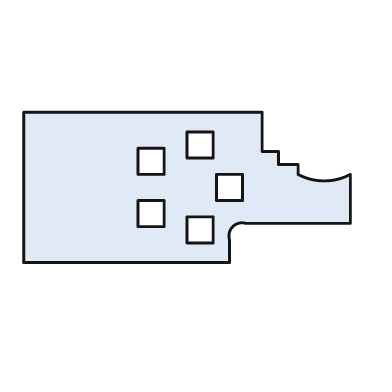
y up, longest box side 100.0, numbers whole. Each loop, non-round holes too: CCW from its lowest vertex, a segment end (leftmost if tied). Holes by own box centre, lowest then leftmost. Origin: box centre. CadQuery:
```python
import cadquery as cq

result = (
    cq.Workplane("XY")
    .moveTo(-50.0, -23.0)
    .lineTo(13.0, -23.0)
    .lineTo(13.0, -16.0)
    .threePointArc((14.0, -12.0), (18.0, -11.0))
    .lineTo(50.0, -11.0)
    .lineTo(50.0, 4.0)
    .threePointArc((42.0, 2.0), (34.0, 4.0))
    .lineTo(34.0, 7.0)
    .lineTo(28.0, 7.0)
    .lineTo(28.0, 11.0)
    .lineTo(23.0, 11.0)
    .lineTo(23.0, 23.0)
    .lineTo(-50.0, 23.0)
    .close()
    .moveTo(0.0, -17.0)
    .lineTo(8.0, -17.0)
    .lineTo(8.0, -9.0)
    .lineTo(0.0, -9.0)
    .close()
    .moveTo(-15.0, -12.0)
    .lineTo(-7.0, -12.0)
    .lineTo(-7.0, -4.0)
    .lineTo(-15.0, -4.0)
    .close()
    .moveTo(9.0, -4.0)
    .lineTo(17.0, -4.0)
    .lineTo(17.0, 4.0)
    .lineTo(9.0, 4.0)
    .close()
    .moveTo(-15.0, 4.0)
    .lineTo(-7.0, 4.0)
    .lineTo(-7.0, 12.0)
    .lineTo(-15.0, 12.0)
    .close()
    .moveTo(0.0, 9.0)
    .lineTo(8.0, 9.0)
    .lineTo(8.0, 17.0)
    .lineTo(0.0, 17.0)
    .close()
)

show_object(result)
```